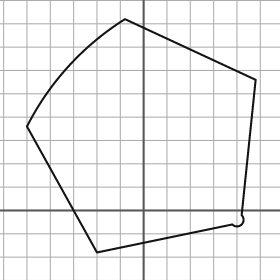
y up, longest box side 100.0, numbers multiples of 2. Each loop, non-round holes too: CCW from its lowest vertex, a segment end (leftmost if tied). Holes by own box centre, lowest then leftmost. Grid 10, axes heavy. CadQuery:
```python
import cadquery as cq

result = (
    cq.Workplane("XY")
    .moveTo(-20.0, -18.0)
    .lineTo(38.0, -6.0)
    .threePointArc((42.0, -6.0), (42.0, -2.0))
    .lineTo(48.0, 56.0)
    .lineTo(-8.0, 82.0)
    .threePointArc((-32.0, 62.0), (-50.0, 36.0))
    .close()
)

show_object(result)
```